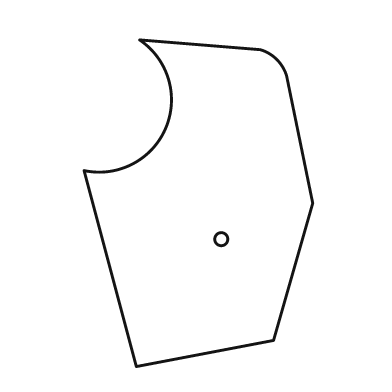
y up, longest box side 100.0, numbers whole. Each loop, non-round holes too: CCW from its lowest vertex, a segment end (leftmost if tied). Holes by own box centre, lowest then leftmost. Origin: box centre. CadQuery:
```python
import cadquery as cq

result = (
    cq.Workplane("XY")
    .moveTo(-19.0, -50.0)
    .lineTo(23.0, -42.0)
    .lineTo(35.0, 0.0)
    .lineTo(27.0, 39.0)
    .threePointArc((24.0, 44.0), (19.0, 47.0))
    .lineTo(-18.0, 50.0)
    .threePointArc((-10.0, 23.0), (-35.0, 10.0))
    .close()
    .moveTo(7.0, -11.0)
    .circle(2.0)
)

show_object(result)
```